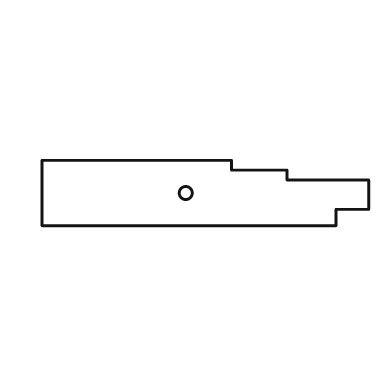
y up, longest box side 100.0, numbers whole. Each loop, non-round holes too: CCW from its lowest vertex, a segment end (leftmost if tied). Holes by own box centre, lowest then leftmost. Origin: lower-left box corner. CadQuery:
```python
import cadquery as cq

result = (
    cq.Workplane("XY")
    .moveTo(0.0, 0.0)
    .lineTo(90.0, 0.0)
    .lineTo(90.0, 5.0)
    .lineTo(100.0, 5.0)
    .lineTo(100.0, 14.0)
    .lineTo(75.0, 14.0)
    .lineTo(75.0, 17.0)
    .lineTo(58.0, 17.0)
    .lineTo(58.0, 20.0)
    .lineTo(0.0, 20.0)
    .close()
    .moveTo(44.0, 10.0)
    .circle(2.0)
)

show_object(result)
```